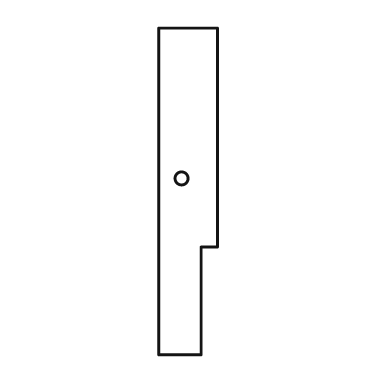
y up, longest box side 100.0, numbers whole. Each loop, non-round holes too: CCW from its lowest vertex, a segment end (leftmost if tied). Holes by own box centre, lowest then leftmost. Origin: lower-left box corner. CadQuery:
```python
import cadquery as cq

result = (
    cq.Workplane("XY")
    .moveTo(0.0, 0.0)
    .lineTo(13.0, 0.0)
    .lineTo(13.0, 33.0)
    .lineTo(18.0, 33.0)
    .lineTo(18.0, 100.0)
    .lineTo(0.0, 100.0)
    .close()
    .moveTo(7.0, 54.0)
    .circle(2.0)
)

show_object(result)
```